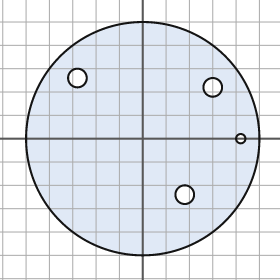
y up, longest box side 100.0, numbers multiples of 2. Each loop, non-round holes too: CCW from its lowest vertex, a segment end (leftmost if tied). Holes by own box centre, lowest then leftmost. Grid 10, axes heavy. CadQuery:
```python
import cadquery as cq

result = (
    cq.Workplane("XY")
    .moveTo(0.0, 0.0)
    .circle(50.0)
    .moveTo(18.0, -24.0)
    .circle(4.0)
    .moveTo(42.0, 0.0)
    .circle(2.0)
    .moveTo(30.0, 22.0)
    .circle(4.0)
    .moveTo(-28.0, 26.0)
    .circle(4.0)
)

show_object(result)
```